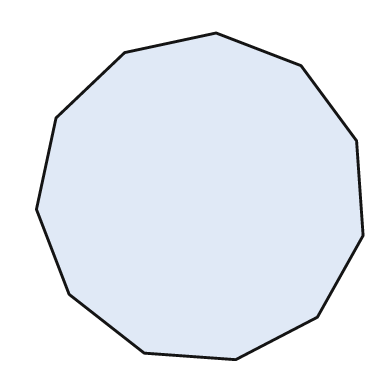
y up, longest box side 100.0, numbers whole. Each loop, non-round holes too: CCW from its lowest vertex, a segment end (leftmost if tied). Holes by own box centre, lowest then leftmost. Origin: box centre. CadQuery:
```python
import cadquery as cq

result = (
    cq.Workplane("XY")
    .moveTo(11.0, -50.0)
    .lineTo(36.0, -37.0)
    .lineTo(50.0, -12.0)
    .lineTo(48.0, 17.0)
    .lineTo(31.0, 40.0)
    .lineTo(5.0, 50.0)
    .lineTo(-23.0, 44.0)
    .lineTo(-44.0, 24.0)
    .lineTo(-50.0, -4.0)
    .lineTo(-40.0, -30.0)
    .lineTo(-17.0, -48.0)
    .close()
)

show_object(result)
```